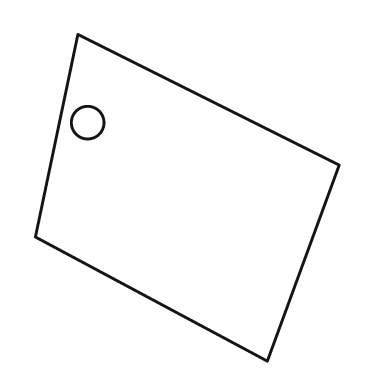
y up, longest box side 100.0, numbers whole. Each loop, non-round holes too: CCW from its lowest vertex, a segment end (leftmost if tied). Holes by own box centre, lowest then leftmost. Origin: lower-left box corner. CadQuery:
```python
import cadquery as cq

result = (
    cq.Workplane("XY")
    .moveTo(71.0, 0.0)
    .lineTo(93.0, 60.0)
    .lineTo(13.0, 100.0)
    .lineTo(0.0, 38.0)
    .close()
    .moveTo(16.0, 73.0)
    .circle(5.0)
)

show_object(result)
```